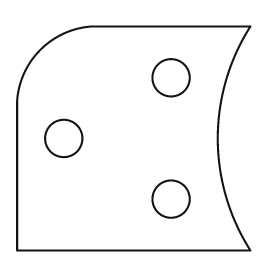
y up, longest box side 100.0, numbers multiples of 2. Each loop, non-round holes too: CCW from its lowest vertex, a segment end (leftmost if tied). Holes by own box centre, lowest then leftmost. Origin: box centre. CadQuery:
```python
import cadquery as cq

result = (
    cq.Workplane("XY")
    .moveTo(-50.0, -48.0)
    .lineTo(50.0, -48.0)
    .threePointArc((36.0, 0.0), (50.0, 48.0))
    .lineTo(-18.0, 48.0)
    .threePointArc((-40.0, 38.0), (-50.0, 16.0))
    .close()
    .moveTo(16.0, -26.0)
    .circle(8.0)
    .moveTo(-30.0, 0.0)
    .circle(8.0)
    .moveTo(16.0, 26.0)
    .circle(8.0)
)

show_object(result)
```